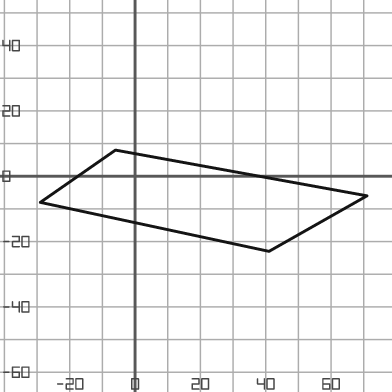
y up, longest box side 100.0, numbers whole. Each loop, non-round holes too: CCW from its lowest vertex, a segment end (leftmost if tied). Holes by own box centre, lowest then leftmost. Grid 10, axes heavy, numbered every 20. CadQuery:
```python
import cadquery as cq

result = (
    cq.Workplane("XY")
    .moveTo(41.0, -23.0)
    .lineTo(71.0, -6.0)
    .lineTo(-6.0, 8.0)
    .lineTo(-29.0, -8.0)
    .close()
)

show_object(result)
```